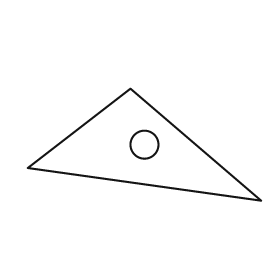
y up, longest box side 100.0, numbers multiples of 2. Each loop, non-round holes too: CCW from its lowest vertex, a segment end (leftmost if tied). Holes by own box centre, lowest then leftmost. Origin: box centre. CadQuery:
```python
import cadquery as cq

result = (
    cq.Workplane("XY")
    .moveTo(50.0, -24.0)
    .lineTo(-6.0, 24.0)
    .lineTo(-50.0, -10.0)
    .close()
    .moveTo(0.0, 0.0)
    .circle(6.0)
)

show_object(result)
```